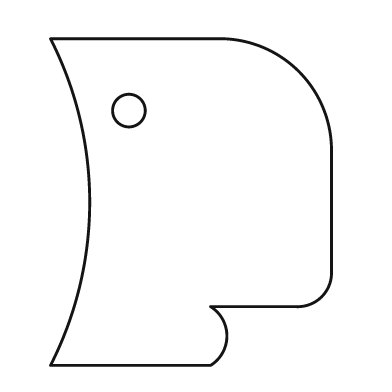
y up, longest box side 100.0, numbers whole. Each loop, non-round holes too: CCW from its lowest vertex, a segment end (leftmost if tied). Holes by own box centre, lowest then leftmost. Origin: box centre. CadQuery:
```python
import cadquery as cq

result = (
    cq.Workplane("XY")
    .moveTo(-43.0, -50.0)
    .lineTo(6.0, -50.0)
    .threePointArc((11.0, -41.0), (6.0, -32.0))
    .lineTo(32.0, -32.0)
    .threePointArc((40.0, -29.0), (43.0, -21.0))
    .lineTo(43.0, 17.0)
    .threePointArc((33.0, 40.0), (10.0, 50.0))
    .lineTo(-43.0, 50.0)
    .threePointArc((-31.0, 0.0), (-43.0, -50.0))
    .close()
    .moveTo(-19.0, 28.0)
    .circle(5.0)
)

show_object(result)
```